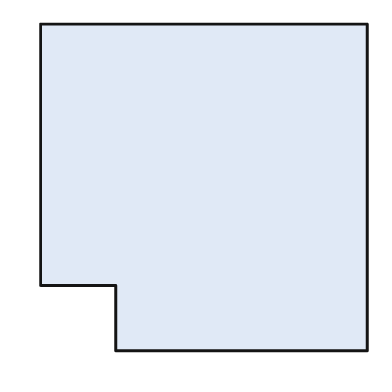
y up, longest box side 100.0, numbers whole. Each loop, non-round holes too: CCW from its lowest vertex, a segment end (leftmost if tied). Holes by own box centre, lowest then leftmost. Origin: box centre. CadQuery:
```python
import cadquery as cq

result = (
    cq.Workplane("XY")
    .moveTo(-27.0, -50.0)
    .lineTo(50.0, -50.0)
    .lineTo(50.0, 50.0)
    .lineTo(-50.0, 50.0)
    .lineTo(-50.0, -30.0)
    .lineTo(-27.0, -30.0)
    .close()
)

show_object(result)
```